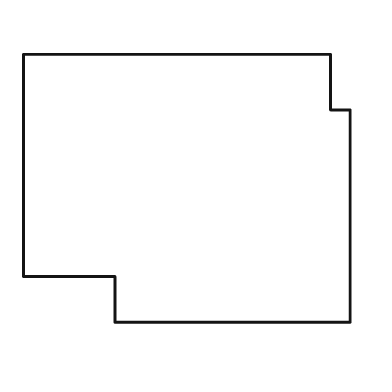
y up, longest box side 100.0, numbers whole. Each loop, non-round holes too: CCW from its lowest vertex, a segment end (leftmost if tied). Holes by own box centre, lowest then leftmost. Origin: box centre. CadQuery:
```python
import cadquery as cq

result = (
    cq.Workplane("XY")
    .moveTo(-22.0, -41.0)
    .lineTo(50.0, -41.0)
    .lineTo(50.0, 24.0)
    .lineTo(44.0, 24.0)
    .lineTo(44.0, 41.0)
    .lineTo(-50.0, 41.0)
    .lineTo(-50.0, -27.0)
    .lineTo(-22.0, -27.0)
    .close()
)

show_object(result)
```